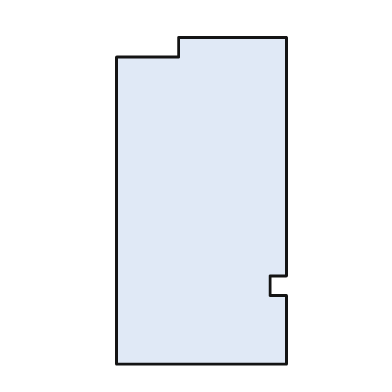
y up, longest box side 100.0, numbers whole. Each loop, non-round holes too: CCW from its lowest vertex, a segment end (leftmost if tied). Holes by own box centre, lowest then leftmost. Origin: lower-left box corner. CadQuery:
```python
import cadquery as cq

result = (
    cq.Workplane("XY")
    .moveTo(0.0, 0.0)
    .lineTo(52.0, 0.0)
    .lineTo(52.0, 21.0)
    .lineTo(47.0, 21.0)
    .lineTo(47.0, 27.0)
    .lineTo(52.0, 27.0)
    .lineTo(52.0, 100.0)
    .lineTo(19.0, 100.0)
    .lineTo(19.0, 94.0)
    .lineTo(0.0, 94.0)
    .close()
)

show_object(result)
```